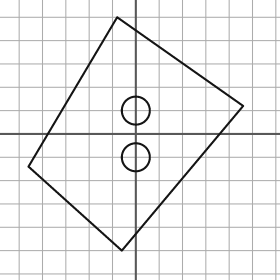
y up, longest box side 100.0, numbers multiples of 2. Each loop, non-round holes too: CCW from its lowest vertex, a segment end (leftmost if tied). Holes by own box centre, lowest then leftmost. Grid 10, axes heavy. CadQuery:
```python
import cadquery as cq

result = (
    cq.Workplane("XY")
    .moveTo(-6.0, -50.0)
    .lineTo(46.0, 12.0)
    .lineTo(-8.0, 50.0)
    .lineTo(-46.0, -14.0)
    .close()
    .moveTo(0.0, -10.0)
    .circle(6.0)
    .moveTo(0.0, 10.0)
    .circle(6.0)
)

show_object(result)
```